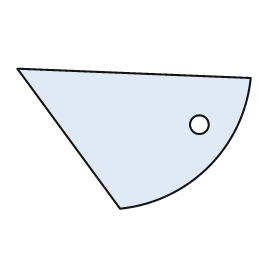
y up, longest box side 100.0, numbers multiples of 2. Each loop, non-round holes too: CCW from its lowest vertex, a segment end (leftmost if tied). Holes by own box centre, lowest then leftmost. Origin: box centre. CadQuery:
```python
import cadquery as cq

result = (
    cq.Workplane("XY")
    .moveTo(-6.0, -30.0)
    .threePointArc((32.0, -12.0), (50.0, 26.0))
    .lineTo(-50.0, 30.0)
    .close()
    .moveTo(28.0, 6.0)
    .circle(4.0)
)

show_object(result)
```